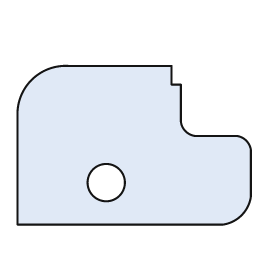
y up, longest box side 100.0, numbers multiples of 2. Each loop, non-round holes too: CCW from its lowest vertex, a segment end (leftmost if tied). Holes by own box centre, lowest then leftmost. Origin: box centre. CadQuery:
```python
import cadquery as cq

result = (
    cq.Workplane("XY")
    .moveTo(-50.0, -34.0)
    .lineTo(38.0, -34.0)
    .threePointArc((46.0, -30.0), (50.0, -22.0))
    .lineTo(50.0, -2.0)
    .threePointArc((48.0, 2.0), (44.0, 4.0))
    .lineTo(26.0, 4.0)
    .threePointArc((22.0, 6.0), (20.0, 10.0))
    .lineTo(20.0, 26.0)
    .lineTo(16.0, 26.0)
    .lineTo(16.0, 34.0)
    .lineTo(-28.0, 34.0)
    .threePointArc((-44.0, 28.0), (-50.0, 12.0))
    .close()
    .moveTo(-12.0, -16.0)
    .circle(8.0)
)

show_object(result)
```